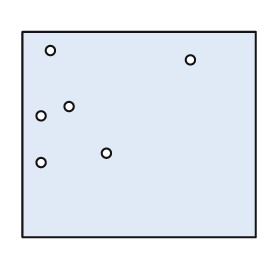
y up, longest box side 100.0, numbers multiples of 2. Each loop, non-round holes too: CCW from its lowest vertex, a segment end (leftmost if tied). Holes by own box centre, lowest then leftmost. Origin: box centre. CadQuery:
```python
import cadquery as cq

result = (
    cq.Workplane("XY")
    .moveTo(-50.0, -44.0)
    .lineTo(50.0, -44.0)
    .lineTo(50.0, 44.0)
    .lineTo(-50.0, 44.0)
    .close()
    .moveTo(-42.0, -12.0)
    .circle(2.0)
    .moveTo(-14.0, -8.0)
    .circle(2.0)
    .moveTo(-42.0, 8.0)
    .circle(2.0)
    .moveTo(-30.0, 12.0)
    .circle(2.0)
    .moveTo(22.0, 32.0)
    .circle(2.0)
    .moveTo(-38.0, 36.0)
    .circle(2.0)
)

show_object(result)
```